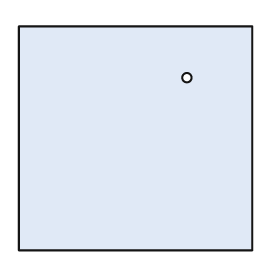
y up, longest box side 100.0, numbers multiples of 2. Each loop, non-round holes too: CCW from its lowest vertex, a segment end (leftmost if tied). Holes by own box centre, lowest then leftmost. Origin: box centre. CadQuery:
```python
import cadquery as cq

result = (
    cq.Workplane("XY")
    .moveTo(-50.0, -48.0)
    .lineTo(50.0, -48.0)
    .lineTo(50.0, 48.0)
    .lineTo(-50.0, 48.0)
    .close()
    .moveTo(22.0, 26.0)
    .circle(2.0)
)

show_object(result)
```